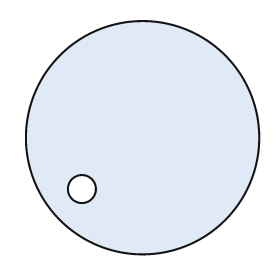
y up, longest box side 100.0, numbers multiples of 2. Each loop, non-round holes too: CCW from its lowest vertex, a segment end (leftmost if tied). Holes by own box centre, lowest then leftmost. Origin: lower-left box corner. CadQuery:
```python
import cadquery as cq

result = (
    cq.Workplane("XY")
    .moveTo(50.0, 50.0)
    .circle(50.0)
    .moveTo(24.0, 28.0)
    .circle(6.0)
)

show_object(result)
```